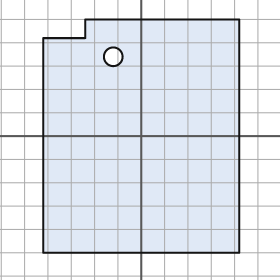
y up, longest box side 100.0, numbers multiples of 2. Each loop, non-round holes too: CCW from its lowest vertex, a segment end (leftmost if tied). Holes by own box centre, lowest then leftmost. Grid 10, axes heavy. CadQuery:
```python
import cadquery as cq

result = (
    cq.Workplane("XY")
    .moveTo(-42.0, -50.0)
    .lineTo(42.0, -50.0)
    .lineTo(42.0, 50.0)
    .lineTo(-24.0, 50.0)
    .lineTo(-24.0, 42.0)
    .lineTo(-42.0, 42.0)
    .close()
    .moveTo(-12.0, 34.0)
    .circle(4.0)
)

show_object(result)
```